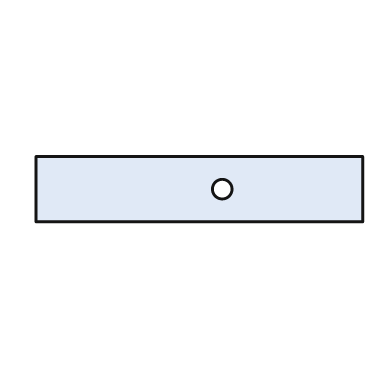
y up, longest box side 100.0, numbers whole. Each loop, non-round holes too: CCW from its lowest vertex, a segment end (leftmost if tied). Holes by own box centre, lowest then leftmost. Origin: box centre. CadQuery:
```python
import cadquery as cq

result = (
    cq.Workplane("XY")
    .moveTo(-50.0, -10.0)
    .lineTo(50.0, -10.0)
    .lineTo(50.0, 10.0)
    .lineTo(-50.0, 10.0)
    .close()
    .moveTo(7.0, 0.0)
    .circle(3.0)
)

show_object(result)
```